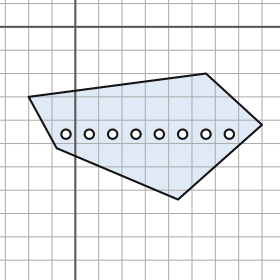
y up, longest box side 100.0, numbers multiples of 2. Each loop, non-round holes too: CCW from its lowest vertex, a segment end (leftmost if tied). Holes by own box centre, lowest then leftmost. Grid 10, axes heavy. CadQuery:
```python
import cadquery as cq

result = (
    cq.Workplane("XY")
    .moveTo(44.0, -74.0)
    .lineTo(80.0, -42.0)
    .lineTo(56.0, -20.0)
    .lineTo(-20.0, -30.0)
    .lineTo(-8.0, -52.0)
    .close()
    .moveTo(-4.0, -46.0)
    .circle(2.0)
    .moveTo(6.0, -46.0)
    .circle(2.0)
    .moveTo(16.0, -46.0)
    .circle(2.0)
    .moveTo(26.0, -46.0)
    .circle(2.0)
    .moveTo(36.0, -46.0)
    .circle(2.0)
    .moveTo(46.0, -46.0)
    .circle(2.0)
    .moveTo(56.0, -46.0)
    .circle(2.0)
    .moveTo(66.0, -46.0)
    .circle(2.0)
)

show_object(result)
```